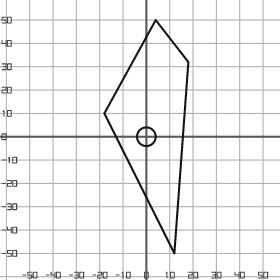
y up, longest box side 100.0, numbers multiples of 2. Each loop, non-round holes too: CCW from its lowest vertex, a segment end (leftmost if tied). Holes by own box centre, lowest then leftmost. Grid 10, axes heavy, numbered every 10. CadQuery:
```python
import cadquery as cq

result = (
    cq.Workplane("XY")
    .moveTo(12.0, -50.0)
    .lineTo(18.0, 32.0)
    .lineTo(4.0, 50.0)
    .lineTo(-18.0, 10.0)
    .close()
    .moveTo(0.0, 0.0)
    .circle(4.0)
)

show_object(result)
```